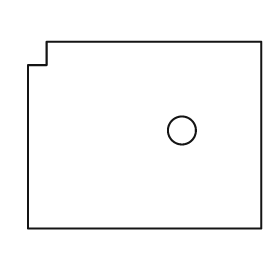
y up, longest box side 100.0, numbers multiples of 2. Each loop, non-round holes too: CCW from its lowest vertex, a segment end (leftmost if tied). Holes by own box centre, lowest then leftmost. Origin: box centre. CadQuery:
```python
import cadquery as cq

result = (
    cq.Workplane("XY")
    .moveTo(-50.0, -40.0)
    .lineTo(50.0, -40.0)
    .lineTo(50.0, 40.0)
    .lineTo(-42.0, 40.0)
    .lineTo(-42.0, 30.0)
    .lineTo(-50.0, 30.0)
    .close()
    .moveTo(16.0, 2.0)
    .circle(6.0)
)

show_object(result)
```